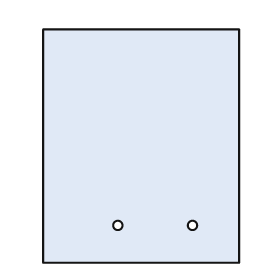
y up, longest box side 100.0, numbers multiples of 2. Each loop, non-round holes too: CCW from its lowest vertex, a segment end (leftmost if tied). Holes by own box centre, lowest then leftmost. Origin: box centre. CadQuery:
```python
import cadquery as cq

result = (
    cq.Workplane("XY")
    .moveTo(-42.0, -50.0)
    .lineTo(42.0, -50.0)
    .lineTo(42.0, 50.0)
    .lineTo(-42.0, 50.0)
    .close()
    .moveTo(-10.0, -34.0)
    .circle(2.0)
    .moveTo(22.0, -34.0)
    .circle(2.0)
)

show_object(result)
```